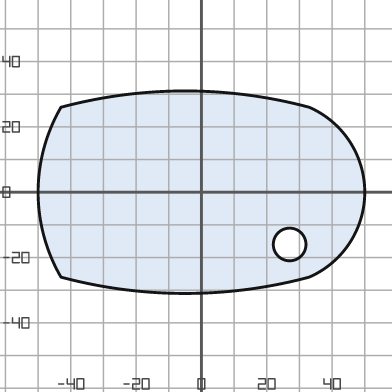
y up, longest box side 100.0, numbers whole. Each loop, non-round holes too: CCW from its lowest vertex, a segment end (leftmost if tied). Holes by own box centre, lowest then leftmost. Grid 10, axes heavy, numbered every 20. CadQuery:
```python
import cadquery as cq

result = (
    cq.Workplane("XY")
    .moveTo(-43.0, -26.0)
    .threePointArc((-5.0, -31.0), (33.0, -26.0))
    .threePointArc((50.0, 0.0), (33.0, 26.0))
    .threePointArc((-5.0, 31.0), (-43.0, 26.0))
    .threePointArc((-50.0, 0.0), (-43.0, -26.0))
    .close()
    .moveTo(27.0, -16.0)
    .circle(5.0)
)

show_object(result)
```